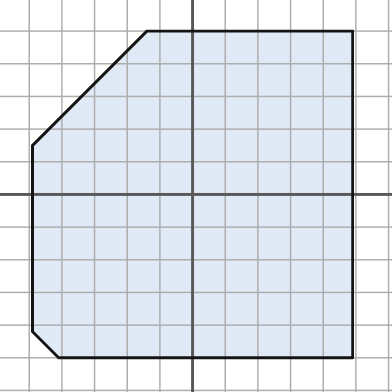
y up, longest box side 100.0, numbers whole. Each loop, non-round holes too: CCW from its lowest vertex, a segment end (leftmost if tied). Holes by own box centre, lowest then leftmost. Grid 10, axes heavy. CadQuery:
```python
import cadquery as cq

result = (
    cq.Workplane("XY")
    .moveTo(-41.0, -50.0)
    .lineTo(49.0, -50.0)
    .lineTo(49.0, 50.0)
    .lineTo(-14.0, 50.0)
    .lineTo(-49.0, 15.0)
    .lineTo(-49.0, -42.0)
    .close()
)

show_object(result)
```